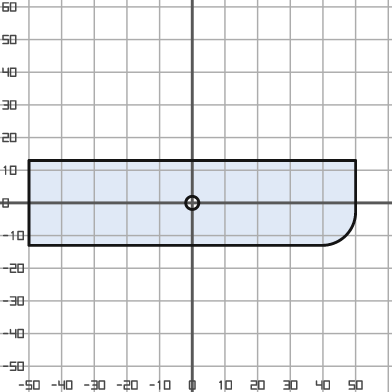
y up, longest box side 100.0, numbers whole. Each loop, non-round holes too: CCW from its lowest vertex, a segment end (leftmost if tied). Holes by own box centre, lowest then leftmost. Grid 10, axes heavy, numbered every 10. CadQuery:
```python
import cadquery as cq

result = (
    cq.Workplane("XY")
    .moveTo(-50.0, -13.0)
    .lineTo(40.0, -13.0)
    .threePointArc((47.0, -10.0), (50.0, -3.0))
    .lineTo(50.0, 13.0)
    .lineTo(-50.0, 13.0)
    .close()
    .moveTo(0.0, 0.0)
    .circle(2.0)
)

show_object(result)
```